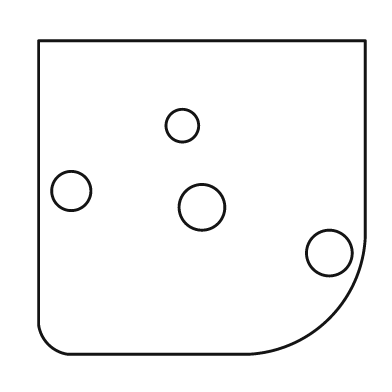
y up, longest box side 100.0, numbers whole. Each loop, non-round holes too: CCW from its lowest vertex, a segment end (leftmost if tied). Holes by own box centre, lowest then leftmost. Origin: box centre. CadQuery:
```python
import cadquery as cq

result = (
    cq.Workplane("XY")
    .moveTo(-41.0, -48.0)
    .lineTo(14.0, -48.0)
    .threePointArc((39.0, -37.0), (50.0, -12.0))
    .lineTo(50.0, 48.0)
    .lineTo(-50.0, 48.0)
    .lineTo(-50.0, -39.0)
    .threePointArc((-47.0, -45.0), (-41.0, -48.0))
    .close()
    .moveTo(39.0, -17.0)
    .circle(7.0)
    .moveTo(0.0, -3.0)
    .circle(7.0)
    .moveTo(-40.0, 2.0)
    .circle(6.0)
    .moveTo(-6.0, 22.0)
    .circle(5.0)
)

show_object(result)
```